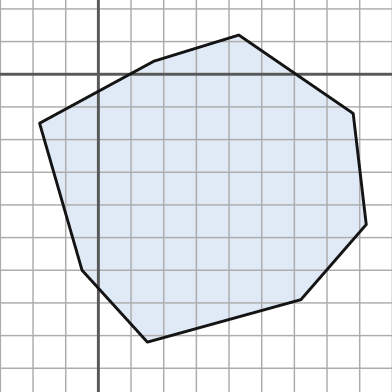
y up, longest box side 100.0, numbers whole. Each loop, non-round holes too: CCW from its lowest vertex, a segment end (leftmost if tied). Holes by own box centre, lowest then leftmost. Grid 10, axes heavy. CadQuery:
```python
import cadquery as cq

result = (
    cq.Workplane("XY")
    .moveTo(15.0, -82.0)
    .lineTo(62.0, -69.0)
    .lineTo(82.0, -46.0)
    .lineTo(78.0, -12.0)
    .lineTo(43.0, 12.0)
    .lineTo(17.0, 4.0)
    .lineTo(-18.0, -15.0)
    .lineTo(-5.0, -60.0)
    .close()
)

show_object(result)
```